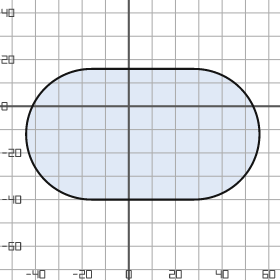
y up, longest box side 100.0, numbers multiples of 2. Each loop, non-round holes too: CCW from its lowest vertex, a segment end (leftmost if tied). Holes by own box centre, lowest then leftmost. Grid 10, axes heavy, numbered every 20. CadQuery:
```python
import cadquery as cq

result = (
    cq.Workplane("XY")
    .moveTo(-16.0, -40.0)
    .lineTo(28.0, -40.0)
    .threePointArc((56.0, -12.0), (28.0, 16.0))
    .lineTo(-16.0, 16.0)
    .threePointArc((-44.0, -12.0), (-16.0, -40.0))
    .close()
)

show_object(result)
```